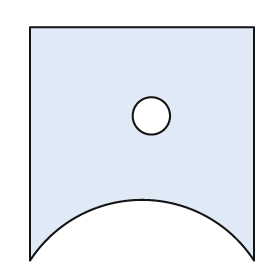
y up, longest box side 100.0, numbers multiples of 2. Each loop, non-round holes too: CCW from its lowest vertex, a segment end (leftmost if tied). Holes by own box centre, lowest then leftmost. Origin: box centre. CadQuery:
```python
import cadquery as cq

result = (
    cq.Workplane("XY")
    .moveTo(-48.0, -50.0)
    .threePointArc((0.0, -24.0), (48.0, -50.0))
    .lineTo(48.0, 50.0)
    .lineTo(-48.0, 50.0)
    .close()
    .moveTo(4.0, 12.0)
    .circle(8.0)
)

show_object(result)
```